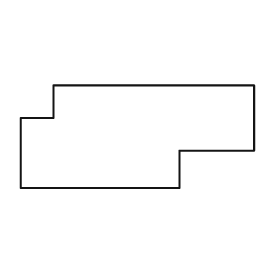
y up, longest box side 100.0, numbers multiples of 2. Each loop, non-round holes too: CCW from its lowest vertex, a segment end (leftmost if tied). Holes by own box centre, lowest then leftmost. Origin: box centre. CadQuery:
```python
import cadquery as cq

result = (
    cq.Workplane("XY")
    .moveTo(-50.0, -22.0)
    .lineTo(18.0, -22.0)
    .lineTo(18.0, -6.0)
    .lineTo(50.0, -6.0)
    .lineTo(50.0, 22.0)
    .lineTo(-36.0, 22.0)
    .lineTo(-36.0, 8.0)
    .lineTo(-50.0, 8.0)
    .close()
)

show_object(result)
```